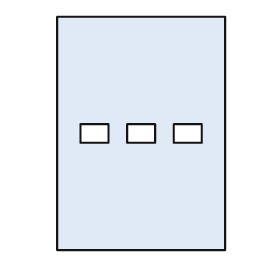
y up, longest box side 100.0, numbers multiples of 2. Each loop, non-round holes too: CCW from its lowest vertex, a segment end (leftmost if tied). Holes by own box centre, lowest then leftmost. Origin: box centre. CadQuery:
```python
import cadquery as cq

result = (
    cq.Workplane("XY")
    .moveTo(-36.0, -50.0)
    .lineTo(36.0, -50.0)
    .lineTo(36.0, 50.0)
    .lineTo(-36.0, 50.0)
    .close()
    .moveTo(-26.0, -4.0)
    .lineTo(-14.0, -4.0)
    .lineTo(-14.0, 4.0)
    .lineTo(-26.0, 4.0)
    .close()
    .moveTo(-6.0, -4.0)
    .lineTo(6.0, -4.0)
    .lineTo(6.0, 4.0)
    .lineTo(-6.0, 4.0)
    .close()
    .moveTo(14.0, -4.0)
    .lineTo(26.0, -4.0)
    .lineTo(26.0, 4.0)
    .lineTo(14.0, 4.0)
    .close()
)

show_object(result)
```